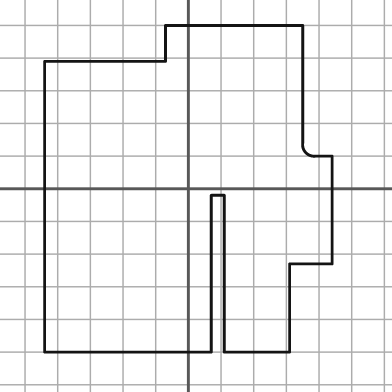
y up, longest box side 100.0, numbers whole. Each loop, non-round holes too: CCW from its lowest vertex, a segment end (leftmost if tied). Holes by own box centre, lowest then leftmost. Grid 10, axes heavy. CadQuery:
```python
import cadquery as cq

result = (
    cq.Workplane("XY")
    .moveTo(-44.0, -50.0)
    .lineTo(7.0, -50.0)
    .lineTo(7.0, -2.0)
    .lineTo(11.0, -2.0)
    .lineTo(11.0, -50.0)
    .lineTo(31.0, -50.0)
    .lineTo(31.0, -23.0)
    .lineTo(44.0, -23.0)
    .lineTo(44.0, 10.0)
    .lineTo(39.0, 10.0)
    .threePointArc((36.0, 11.0), (35.0, 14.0))
    .lineTo(35.0, 50.0)
    .lineTo(-7.0, 50.0)
    .lineTo(-7.0, 39.0)
    .lineTo(-44.0, 39.0)
    .close()
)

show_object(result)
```